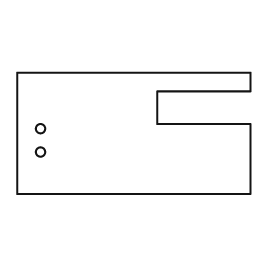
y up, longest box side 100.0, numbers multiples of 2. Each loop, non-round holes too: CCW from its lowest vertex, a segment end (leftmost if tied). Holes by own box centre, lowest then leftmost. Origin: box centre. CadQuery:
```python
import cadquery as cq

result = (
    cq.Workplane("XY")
    .moveTo(-50.0, -26.0)
    .lineTo(50.0, -26.0)
    .lineTo(50.0, 4.0)
    .lineTo(10.0, 4.0)
    .lineTo(10.0, 18.0)
    .lineTo(50.0, 18.0)
    .lineTo(50.0, 26.0)
    .lineTo(-50.0, 26.0)
    .close()
    .moveTo(-40.0, -8.0)
    .circle(2.0)
    .moveTo(-40.0, 2.0)
    .circle(2.0)
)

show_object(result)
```